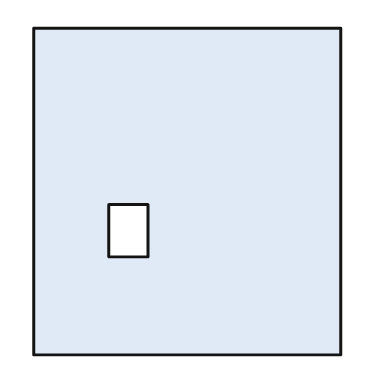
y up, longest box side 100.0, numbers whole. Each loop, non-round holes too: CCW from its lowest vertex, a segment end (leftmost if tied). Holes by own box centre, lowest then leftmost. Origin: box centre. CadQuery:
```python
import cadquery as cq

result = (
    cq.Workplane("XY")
    .moveTo(-47.0, -50.0)
    .lineTo(47.0, -50.0)
    .lineTo(47.0, 50.0)
    .lineTo(-47.0, 50.0)
    .close()
    .moveTo(-24.0, -20.0)
    .lineTo(-12.0, -20.0)
    .lineTo(-12.0, -4.0)
    .lineTo(-24.0, -4.0)
    .close()
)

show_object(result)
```